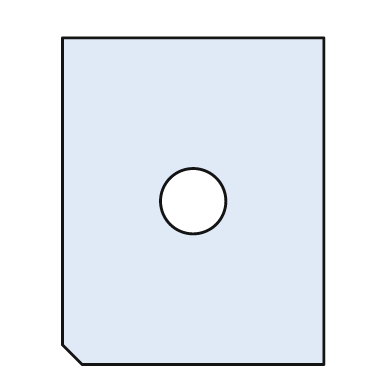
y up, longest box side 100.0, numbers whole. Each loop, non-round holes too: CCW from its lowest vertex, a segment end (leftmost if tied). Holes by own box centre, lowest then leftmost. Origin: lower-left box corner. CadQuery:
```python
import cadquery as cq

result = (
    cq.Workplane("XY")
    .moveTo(6.0, 0.0)
    .lineTo(80.0, 0.0)
    .lineTo(80.0, 100.0)
    .lineTo(0.0, 100.0)
    .lineTo(0.0, 6.0)
    .close()
    .moveTo(40.0, 50.0)
    .circle(10.0)
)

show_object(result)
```